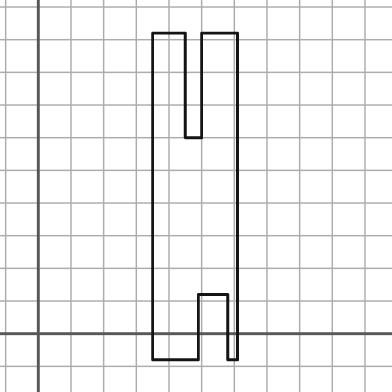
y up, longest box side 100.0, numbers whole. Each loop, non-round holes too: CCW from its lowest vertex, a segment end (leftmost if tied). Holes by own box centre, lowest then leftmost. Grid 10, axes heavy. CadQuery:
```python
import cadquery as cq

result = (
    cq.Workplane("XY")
    .moveTo(35.0, -8.0)
    .lineTo(49.0, -8.0)
    .lineTo(49.0, 12.0)
    .lineTo(58.0, 12.0)
    .lineTo(58.0, -8.0)
    .lineTo(61.0, -8.0)
    .lineTo(61.0, 92.0)
    .lineTo(50.0, 92.0)
    .lineTo(50.0, 60.0)
    .lineTo(45.0, 60.0)
    .lineTo(45.0, 92.0)
    .lineTo(35.0, 92.0)
    .close()
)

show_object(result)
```